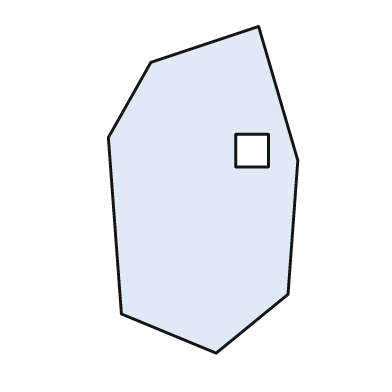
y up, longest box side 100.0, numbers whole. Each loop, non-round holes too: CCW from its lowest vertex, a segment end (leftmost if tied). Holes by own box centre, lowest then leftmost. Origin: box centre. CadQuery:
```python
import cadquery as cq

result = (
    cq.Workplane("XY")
    .moveTo(4.0, -50.0)
    .lineTo(26.0, -32.0)
    .lineTo(29.0, 9.0)
    .lineTo(17.0, 50.0)
    .lineTo(-16.0, 39.0)
    .lineTo(-29.0, 16.0)
    .lineTo(-25.0, -38.0)
    .close()
    .moveTo(10.0, 7.0)
    .lineTo(20.0, 7.0)
    .lineTo(20.0, 17.0)
    .lineTo(10.0, 17.0)
    .close()
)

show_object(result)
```